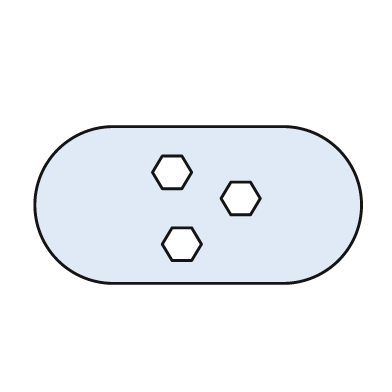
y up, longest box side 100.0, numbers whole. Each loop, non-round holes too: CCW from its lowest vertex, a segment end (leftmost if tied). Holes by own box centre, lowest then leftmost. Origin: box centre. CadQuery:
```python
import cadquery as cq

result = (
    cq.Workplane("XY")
    .moveTo(-26.0, -24.0)
    .lineTo(26.0, -24.0)
    .threePointArc((50.0, 0.0), (26.0, 24.0))
    .lineTo(-26.0, 24.0)
    .threePointArc((-50.0, 0.0), (-26.0, -24.0))
    .close()
    .moveTo(-8.0, -17.0)
    .lineTo(-2.0, -17.0)
    .lineTo(1.0, -12.0)
    .lineTo(-2.0, -7.0)
    .lineTo(-8.0, -7.0)
    .lineTo(-11.0, -12.0)
    .close()
    .moveTo(10.0, -3.0)
    .lineTo(16.0, -3.0)
    .lineTo(19.0, 2.0)
    .lineTo(16.0, 7.0)
    .lineTo(10.0, 7.0)
    .lineTo(7.0, 2.0)
    .close()
    .moveTo(-11.0, 5.0)
    .lineTo(-5.0, 5.0)
    .lineTo(-2.0, 10.0)
    .lineTo(-5.0, 15.0)
    .lineTo(-11.0, 15.0)
    .lineTo(-14.0, 10.0)
    .close()
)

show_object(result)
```